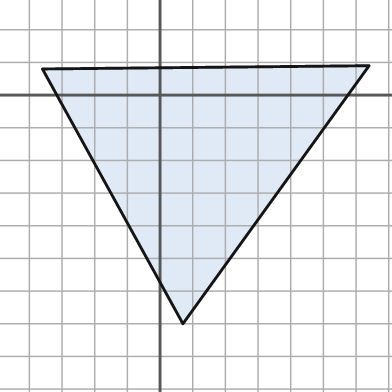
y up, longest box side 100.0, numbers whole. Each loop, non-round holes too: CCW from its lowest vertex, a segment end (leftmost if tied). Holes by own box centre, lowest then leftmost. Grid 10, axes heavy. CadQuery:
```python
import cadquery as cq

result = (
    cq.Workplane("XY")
    .moveTo(7.0, -70.0)
    .lineTo(64.0, 9.0)
    .lineTo(-36.0, 8.0)
    .close()
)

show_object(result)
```